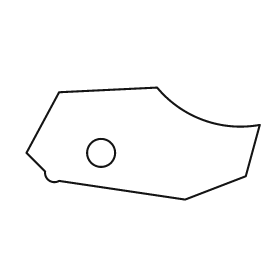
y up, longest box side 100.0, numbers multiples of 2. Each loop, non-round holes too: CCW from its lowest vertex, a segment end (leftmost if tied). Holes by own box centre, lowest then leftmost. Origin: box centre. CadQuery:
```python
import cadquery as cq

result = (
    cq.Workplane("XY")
    .moveTo(18.0, -24.0)
    .lineTo(44.0, -14.0)
    .lineTo(50.0, 8.0)
    .threePointArc((26.0, 10.0), (6.0, 24.0))
    .lineTo(-36.0, 22.0)
    .lineTo(-50.0, -4.0)
    .lineTo(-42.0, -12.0)
    .threePointArc((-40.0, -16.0), (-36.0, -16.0))
    .close()
    .moveTo(-18.0, -4.0)
    .circle(6.0)
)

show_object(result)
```